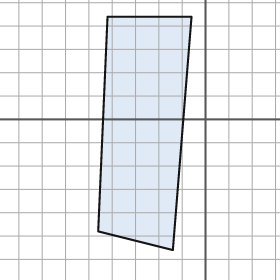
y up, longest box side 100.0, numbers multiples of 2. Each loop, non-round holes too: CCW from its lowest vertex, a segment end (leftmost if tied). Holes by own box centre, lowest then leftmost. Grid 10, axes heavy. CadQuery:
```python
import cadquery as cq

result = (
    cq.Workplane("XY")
    .moveTo(-14.0, -56.0)
    .lineTo(-6.0, 44.0)
    .lineTo(-42.0, 44.0)
    .lineTo(-46.0, -48.0)
    .close()
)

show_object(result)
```